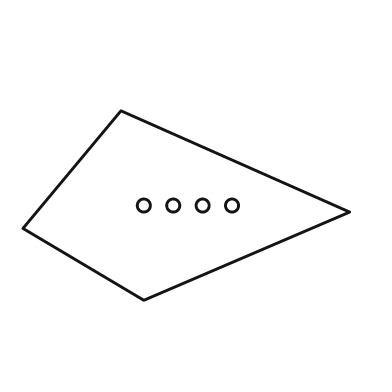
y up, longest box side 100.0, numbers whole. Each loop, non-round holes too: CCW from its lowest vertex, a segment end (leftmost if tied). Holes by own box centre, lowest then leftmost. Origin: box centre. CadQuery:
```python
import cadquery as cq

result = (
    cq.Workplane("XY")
    .moveTo(-13.0, -29.0)
    .lineTo(50.0, -2.0)
    .lineTo(-20.0, 29.0)
    .lineTo(-50.0, -7.0)
    .close()
    .moveTo(-13.0, 0.0)
    .circle(2.0)
    .moveTo(-4.0, 0.0)
    .circle(2.0)
    .moveTo(5.0, 0.0)
    .circle(2.0)
    .moveTo(14.0, 0.0)
    .circle(2.0)
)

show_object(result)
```